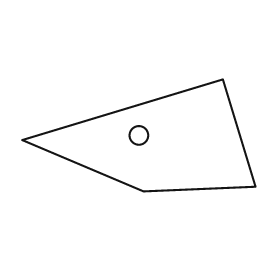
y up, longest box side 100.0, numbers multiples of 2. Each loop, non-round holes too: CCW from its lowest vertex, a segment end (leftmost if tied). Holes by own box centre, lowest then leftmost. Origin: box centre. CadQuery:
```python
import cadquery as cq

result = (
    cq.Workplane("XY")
    .moveTo(2.0, -24.0)
    .lineTo(50.0, -22.0)
    .lineTo(36.0, 24.0)
    .lineTo(-50.0, -2.0)
    .close()
    .moveTo(0.0, 0.0)
    .circle(4.0)
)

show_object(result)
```